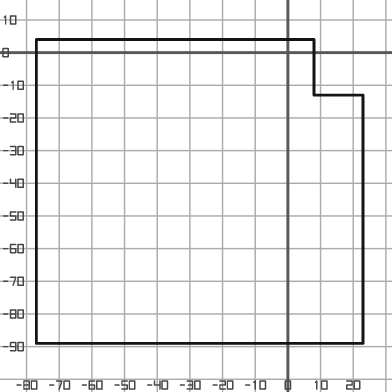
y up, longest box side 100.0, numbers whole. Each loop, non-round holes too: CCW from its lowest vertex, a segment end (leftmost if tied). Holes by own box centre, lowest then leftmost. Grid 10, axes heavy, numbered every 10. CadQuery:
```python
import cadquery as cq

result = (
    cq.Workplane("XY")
    .moveTo(-77.0, -89.0)
    .lineTo(23.0, -89.0)
    .lineTo(23.0, -13.0)
    .lineTo(8.0, -13.0)
    .lineTo(8.0, 4.0)
    .lineTo(-77.0, 4.0)
    .close()
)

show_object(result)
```